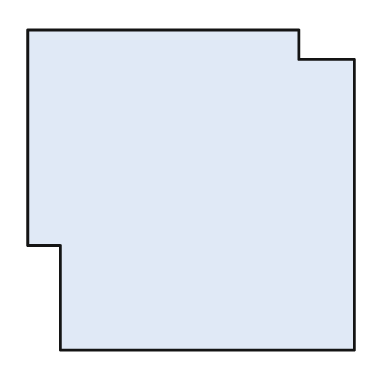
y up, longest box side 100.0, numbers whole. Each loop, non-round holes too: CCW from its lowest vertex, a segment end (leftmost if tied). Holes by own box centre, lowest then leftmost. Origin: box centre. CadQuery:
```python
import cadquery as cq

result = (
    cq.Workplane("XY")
    .moveTo(-40.0, -49.0)
    .lineTo(50.0, -49.0)
    .lineTo(50.0, 40.0)
    .lineTo(33.0, 40.0)
    .lineTo(33.0, 49.0)
    .lineTo(-50.0, 49.0)
    .lineTo(-50.0, -17.0)
    .lineTo(-40.0, -17.0)
    .close()
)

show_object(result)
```